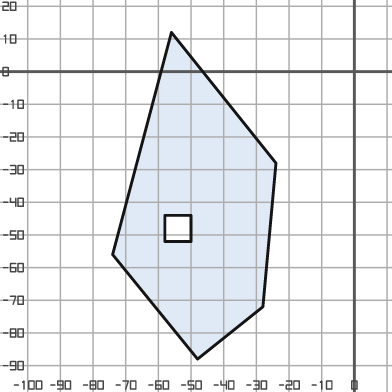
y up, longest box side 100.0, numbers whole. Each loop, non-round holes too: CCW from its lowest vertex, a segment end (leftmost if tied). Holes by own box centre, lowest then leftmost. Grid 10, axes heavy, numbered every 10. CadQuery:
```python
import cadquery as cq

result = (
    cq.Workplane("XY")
    .moveTo(-48.0, -88.0)
    .lineTo(-28.0, -72.0)
    .lineTo(-24.0, -28.0)
    .lineTo(-56.0, 12.0)
    .lineTo(-74.0, -56.0)
    .close()
    .moveTo(-58.0, -52.0)
    .lineTo(-50.0, -52.0)
    .lineTo(-50.0, -44.0)
    .lineTo(-58.0, -44.0)
    .close()
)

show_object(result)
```